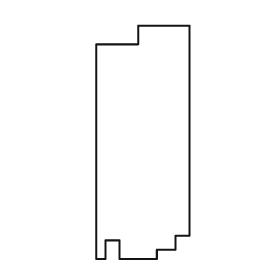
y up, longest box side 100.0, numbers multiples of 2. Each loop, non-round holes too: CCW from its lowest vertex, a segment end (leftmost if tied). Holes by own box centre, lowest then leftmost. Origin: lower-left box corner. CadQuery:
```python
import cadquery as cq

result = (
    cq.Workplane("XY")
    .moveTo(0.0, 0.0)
    .lineTo(4.0, 0.0)
    .lineTo(4.0, 8.0)
    .lineTo(10.0, 8.0)
    .lineTo(10.0, 0.0)
    .lineTo(26.0, 0.0)
    .lineTo(26.0, 4.0)
    .lineTo(34.0, 4.0)
    .lineTo(34.0, 10.0)
    .lineTo(40.0, 10.0)
    .lineTo(40.0, 100.0)
    .lineTo(18.0, 100.0)
    .lineTo(18.0, 92.0)
    .lineTo(0.0, 92.0)
    .close()
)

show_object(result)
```